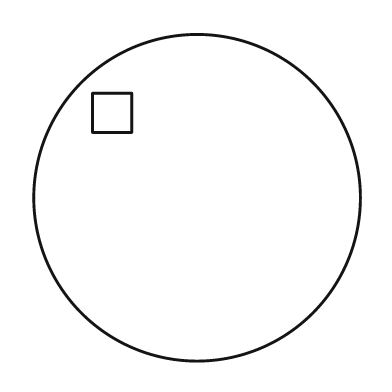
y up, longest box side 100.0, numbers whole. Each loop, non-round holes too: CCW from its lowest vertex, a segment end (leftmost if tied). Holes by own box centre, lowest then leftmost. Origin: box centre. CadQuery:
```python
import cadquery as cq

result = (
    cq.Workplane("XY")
    .moveTo(0.0, 0.0)
    .circle(50.0)
    .moveTo(-32.0, 20.0)
    .lineTo(-20.0, 20.0)
    .lineTo(-20.0, 32.0)
    .lineTo(-32.0, 32.0)
    .close()
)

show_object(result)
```